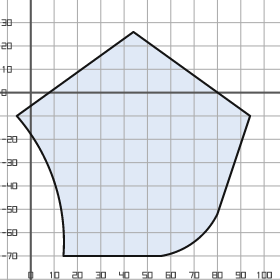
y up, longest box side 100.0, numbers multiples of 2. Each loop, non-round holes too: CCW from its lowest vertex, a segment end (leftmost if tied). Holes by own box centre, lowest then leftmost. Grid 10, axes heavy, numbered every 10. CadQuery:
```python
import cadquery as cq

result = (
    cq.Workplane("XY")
    .moveTo(14.0, -70.0)
    .lineTo(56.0, -70.0)
    .threePointArc((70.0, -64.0), (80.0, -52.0))
    .lineTo(94.0, -10.0)
    .lineTo(44.0, 26.0)
    .lineTo(-6.0, -10.0)
    .threePointArc((10.0, -38.0), (14.0, -70.0))
    .close()
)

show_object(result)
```